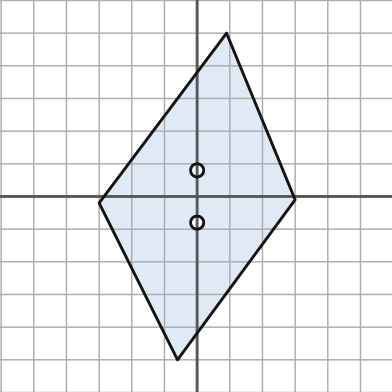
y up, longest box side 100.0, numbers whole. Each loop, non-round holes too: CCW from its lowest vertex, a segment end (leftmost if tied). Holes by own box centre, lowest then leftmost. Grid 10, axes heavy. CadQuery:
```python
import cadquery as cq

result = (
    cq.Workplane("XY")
    .moveTo(-6.0, -50.0)
    .lineTo(30.0, -1.0)
    .lineTo(9.0, 50.0)
    .lineTo(-30.0, -2.0)
    .close()
    .moveTo(0.0, -8.0)
    .circle(2.0)
    .moveTo(0.0, 8.0)
    .circle(2.0)
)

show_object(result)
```